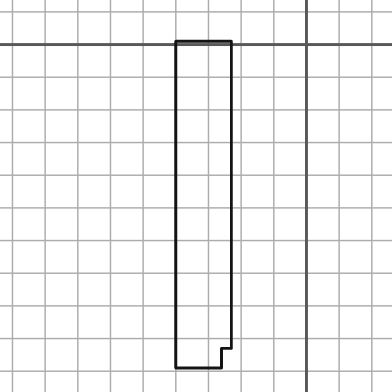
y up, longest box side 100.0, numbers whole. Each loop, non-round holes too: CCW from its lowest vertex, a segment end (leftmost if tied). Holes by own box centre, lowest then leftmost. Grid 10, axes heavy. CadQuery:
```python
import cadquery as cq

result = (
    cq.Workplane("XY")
    .moveTo(-40.0, -99.0)
    .lineTo(-26.0, -99.0)
    .lineTo(-26.0, -93.0)
    .lineTo(-23.0, -93.0)
    .lineTo(-23.0, 1.0)
    .lineTo(-40.0, 1.0)
    .close()
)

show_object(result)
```